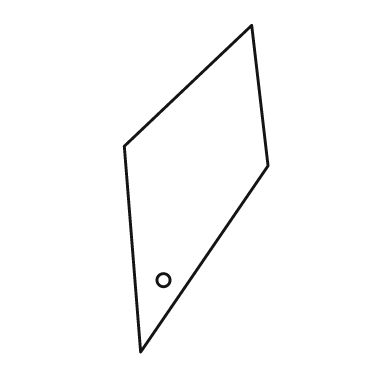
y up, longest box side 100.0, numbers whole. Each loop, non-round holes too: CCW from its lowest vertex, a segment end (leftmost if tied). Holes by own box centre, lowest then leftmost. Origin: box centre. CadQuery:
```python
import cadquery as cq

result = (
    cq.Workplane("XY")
    .moveTo(-17.0, -50.0)
    .lineTo(22.0, 7.0)
    .lineTo(17.0, 50.0)
    .lineTo(-22.0, 13.0)
    .close()
    .moveTo(-10.0, -28.0)
    .circle(2.0)
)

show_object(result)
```